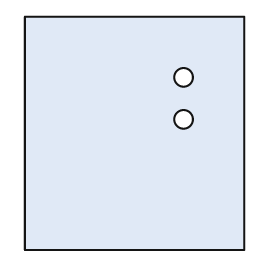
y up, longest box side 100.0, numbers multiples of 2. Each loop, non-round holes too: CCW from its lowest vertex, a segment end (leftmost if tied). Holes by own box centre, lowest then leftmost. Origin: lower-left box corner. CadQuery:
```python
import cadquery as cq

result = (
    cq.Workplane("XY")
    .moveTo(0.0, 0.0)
    .lineTo(94.0, 0.0)
    .lineTo(94.0, 100.0)
    .lineTo(0.0, 100.0)
    .close()
    .moveTo(68.0, 56.0)
    .circle(4.0)
    .moveTo(68.0, 74.0)
    .circle(4.0)
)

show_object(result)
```